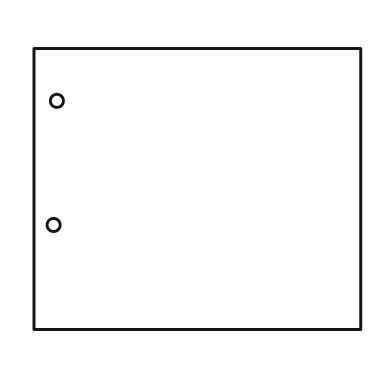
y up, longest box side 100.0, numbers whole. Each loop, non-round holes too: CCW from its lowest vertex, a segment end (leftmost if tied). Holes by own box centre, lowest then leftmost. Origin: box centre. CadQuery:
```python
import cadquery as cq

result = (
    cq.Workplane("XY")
    .moveTo(-50.0, -43.0)
    .lineTo(50.0, -43.0)
    .lineTo(50.0, 43.0)
    .lineTo(-50.0, 43.0)
    .close()
    .moveTo(-44.0, -11.0)
    .circle(2.0)
    .moveTo(-43.0, 27.0)
    .circle(2.0)
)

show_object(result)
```